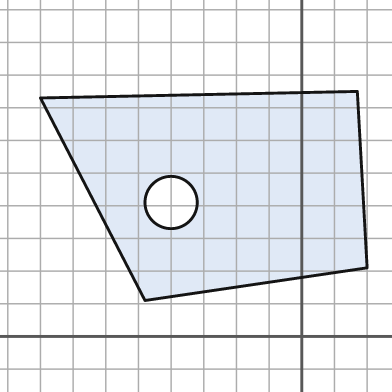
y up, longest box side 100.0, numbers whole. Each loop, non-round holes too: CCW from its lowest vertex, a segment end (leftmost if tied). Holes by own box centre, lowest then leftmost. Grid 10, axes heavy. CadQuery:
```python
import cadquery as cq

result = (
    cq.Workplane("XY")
    .moveTo(-48.0, 11.0)
    .lineTo(20.0, 21.0)
    .lineTo(17.0, 75.0)
    .lineTo(-80.0, 73.0)
    .close()
    .moveTo(-40.0, 41.0)
    .circle(8.0)
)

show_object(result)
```